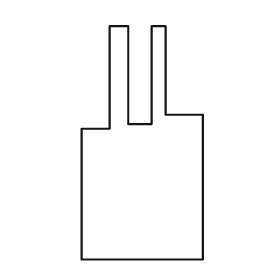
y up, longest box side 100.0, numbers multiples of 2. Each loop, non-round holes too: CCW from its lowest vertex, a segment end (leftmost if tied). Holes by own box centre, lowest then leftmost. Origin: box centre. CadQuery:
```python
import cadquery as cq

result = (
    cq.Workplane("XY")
    .moveTo(-26.0, -50.0)
    .lineTo(26.0, -50.0)
    .lineTo(26.0, 12.0)
    .lineTo(10.0, 12.0)
    .lineTo(10.0, 50.0)
    .lineTo(4.0, 50.0)
    .lineTo(4.0, 8.0)
    .lineTo(-6.0, 8.0)
    .lineTo(-6.0, 50.0)
    .lineTo(-14.0, 50.0)
    .lineTo(-14.0, 6.0)
    .lineTo(-26.0, 6.0)
    .close()
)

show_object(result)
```